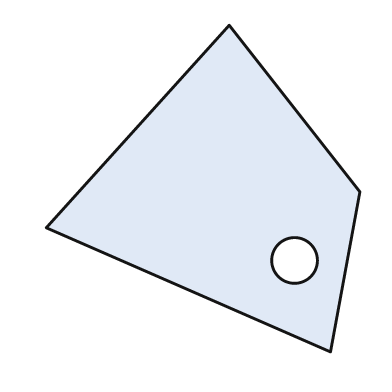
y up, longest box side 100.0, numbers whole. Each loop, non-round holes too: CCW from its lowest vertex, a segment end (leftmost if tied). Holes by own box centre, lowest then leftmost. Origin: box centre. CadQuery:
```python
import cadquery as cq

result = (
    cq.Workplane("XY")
    .moveTo(39.0, -50.0)
    .lineTo(48.0, -1.0)
    .lineTo(8.0, 50.0)
    .lineTo(-48.0, -12.0)
    .close()
    .moveTo(28.0, -22.0)
    .circle(7.0)
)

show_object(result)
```